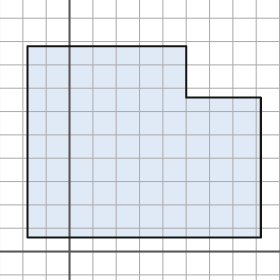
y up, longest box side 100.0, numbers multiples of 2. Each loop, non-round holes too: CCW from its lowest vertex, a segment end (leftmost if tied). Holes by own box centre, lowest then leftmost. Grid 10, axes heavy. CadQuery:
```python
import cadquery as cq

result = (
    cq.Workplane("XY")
    .moveTo(-18.0, 6.0)
    .lineTo(82.0, 6.0)
    .lineTo(82.0, 66.0)
    .lineTo(50.0, 66.0)
    .lineTo(50.0, 88.0)
    .lineTo(-18.0, 88.0)
    .close()
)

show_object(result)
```